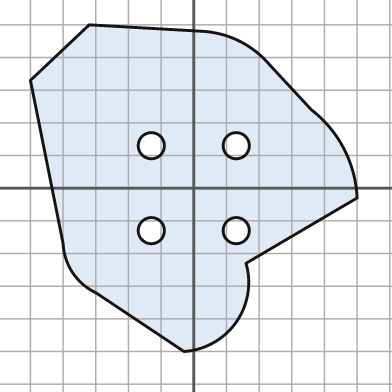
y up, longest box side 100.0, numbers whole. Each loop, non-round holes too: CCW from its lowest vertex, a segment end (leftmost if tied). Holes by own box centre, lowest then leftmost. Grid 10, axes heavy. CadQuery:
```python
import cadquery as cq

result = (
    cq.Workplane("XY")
    .moveTo(-3.0, -50.0)
    .threePointArc((13.0, -41.0), (16.0, -23.0))
    .lineTo(50.0, -3.0)
    .threePointArc((46.0, 12.0), (36.0, 24.0))
    .lineTo(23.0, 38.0)
    .threePointArc((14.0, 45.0), (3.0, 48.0))
    .lineTo(-32.0, 50.0)
    .lineTo(-50.0, 33.0)
    .lineTo(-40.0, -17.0)
    .threePointArc((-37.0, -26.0), (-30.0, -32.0))
    .close()
    .moveTo(-13.0, -13.0)
    .circle(4.0)
    .moveTo(13.0, -13.0)
    .circle(4.0)
    .moveTo(-13.0, 13.0)
    .circle(4.0)
    .moveTo(13.0, 13.0)
    .circle(4.0)
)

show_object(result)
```